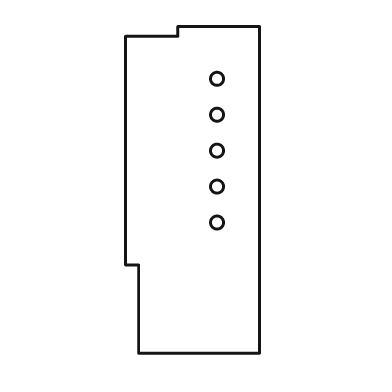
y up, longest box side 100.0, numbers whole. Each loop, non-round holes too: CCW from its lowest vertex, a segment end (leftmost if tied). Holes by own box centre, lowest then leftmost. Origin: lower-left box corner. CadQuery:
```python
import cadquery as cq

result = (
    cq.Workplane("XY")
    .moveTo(4.0, 0.0)
    .lineTo(41.0, 0.0)
    .lineTo(41.0, 100.0)
    .lineTo(16.0, 100.0)
    .lineTo(16.0, 97.0)
    .lineTo(0.0, 97.0)
    .lineTo(0.0, 27.0)
    .lineTo(4.0, 27.0)
    .close()
    .moveTo(28.0, 40.0)
    .circle(2.0)
    .moveTo(28.0, 51.0)
    .circle(2.0)
    .moveTo(28.0, 62.0)
    .circle(2.0)
    .moveTo(28.0, 73.0)
    .circle(2.0)
    .moveTo(28.0, 84.0)
    .circle(2.0)
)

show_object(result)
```